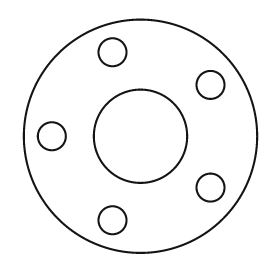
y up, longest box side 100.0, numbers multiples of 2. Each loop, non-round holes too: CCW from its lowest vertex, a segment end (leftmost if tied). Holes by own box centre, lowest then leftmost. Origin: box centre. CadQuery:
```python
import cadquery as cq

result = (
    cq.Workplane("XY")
    .moveTo(0.0, 0.0)
    .circle(50.0)
    .moveTo(-12.0, -36.0)
    .circle(6.0)
    .moveTo(30.0, -22.0)
    .circle(6.0)
    .moveTo(-38.0, 0.0)
    .circle(6.0)
    .moveTo(0.0, 0.0)
    .circle(20.0)
    .moveTo(30.0, 22.0)
    .circle(6.0)
    .moveTo(-12.0, 36.0)
    .circle(6.0)
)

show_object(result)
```